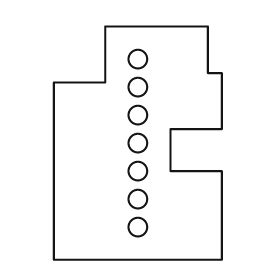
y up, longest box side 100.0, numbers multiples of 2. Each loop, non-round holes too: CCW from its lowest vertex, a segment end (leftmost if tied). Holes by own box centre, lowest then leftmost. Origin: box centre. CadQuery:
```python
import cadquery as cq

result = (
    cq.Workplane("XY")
    .moveTo(-36.0, -50.0)
    .lineTo(36.0, -50.0)
    .lineTo(36.0, -12.0)
    .lineTo(14.0, -12.0)
    .lineTo(14.0, 6.0)
    .lineTo(36.0, 6.0)
    .lineTo(36.0, 30.0)
    .lineTo(30.0, 30.0)
    .lineTo(30.0, 50.0)
    .lineTo(-14.0, 50.0)
    .lineTo(-14.0, 26.0)
    .lineTo(-36.0, 26.0)
    .close()
    .moveTo(0.0, -36.0)
    .circle(4.0)
    .moveTo(0.0, -24.0)
    .circle(4.0)
    .moveTo(0.0, -12.0)
    .circle(4.0)
    .moveTo(0.0, 0.0)
    .circle(4.0)
    .moveTo(0.0, 12.0)
    .circle(4.0)
    .moveTo(0.0, 24.0)
    .circle(4.0)
    .moveTo(0.0, 36.0)
    .circle(4.0)
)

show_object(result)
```